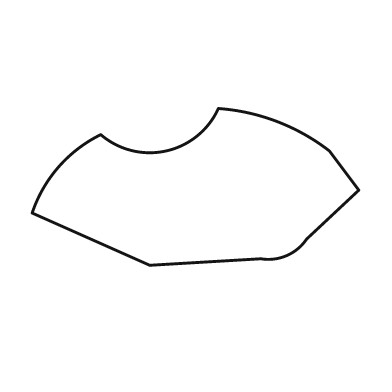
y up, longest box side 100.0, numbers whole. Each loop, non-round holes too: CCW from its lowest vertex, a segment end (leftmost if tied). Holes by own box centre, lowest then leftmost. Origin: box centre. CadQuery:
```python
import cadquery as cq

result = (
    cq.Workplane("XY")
    .moveTo(-14.0, -24.0)
    .lineTo(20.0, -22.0)
    .threePointArc((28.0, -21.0), (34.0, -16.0))
    .lineTo(50.0, -1.0)
    .lineTo(41.0, 11.0)
    .threePointArc((25.0, 20.0), (7.0, 24.0))
    .threePointArc((-9.0, 11.0), (-29.0, 16.0))
    .threePointArc((-42.0, 6.0), (-50.0, -8.0))
    .close()
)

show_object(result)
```